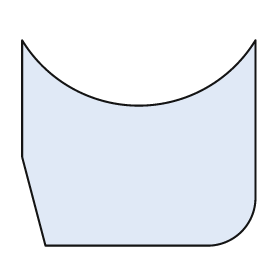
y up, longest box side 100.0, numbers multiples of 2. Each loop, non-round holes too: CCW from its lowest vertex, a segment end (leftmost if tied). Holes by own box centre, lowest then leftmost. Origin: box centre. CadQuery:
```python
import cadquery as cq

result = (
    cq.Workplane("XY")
    .moveTo(-40.0, -44.0)
    .lineTo(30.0, -44.0)
    .threePointArc((44.0, -38.0), (50.0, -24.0))
    .lineTo(50.0, 44.0)
    .threePointArc((0.0, 16.0), (-50.0, 44.0))
    .lineTo(-50.0, -6.0)
    .close()
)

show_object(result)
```